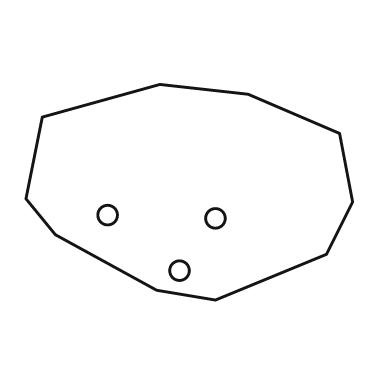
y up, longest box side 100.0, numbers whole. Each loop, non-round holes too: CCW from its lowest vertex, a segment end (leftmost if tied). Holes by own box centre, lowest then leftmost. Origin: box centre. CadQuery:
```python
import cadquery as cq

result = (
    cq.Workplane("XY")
    .moveTo(8.0, -33.0)
    .lineTo(42.0, -19.0)
    .lineTo(50.0, -3.0)
    .lineTo(46.0, 18.0)
    .lineTo(18.0, 30.0)
    .lineTo(-9.0, 33.0)
    .lineTo(-45.0, 23.0)
    .lineTo(-50.0, -2.0)
    .lineTo(-41.0, -13.0)
    .lineTo(-10.0, -30.0)
    .close()
    .moveTo(-3.0, -24.0)
    .circle(3.0)
    .moveTo(8.0, -8.0)
    .circle(3.0)
    .moveTo(-25.0, -7.0)
    .circle(3.0)
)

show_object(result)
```